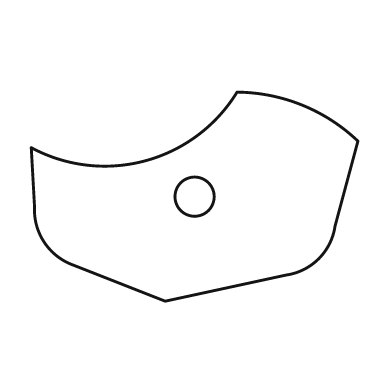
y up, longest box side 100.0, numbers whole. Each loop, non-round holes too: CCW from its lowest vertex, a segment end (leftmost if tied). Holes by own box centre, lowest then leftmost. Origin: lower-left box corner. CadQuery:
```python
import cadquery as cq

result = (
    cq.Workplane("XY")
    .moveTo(41.0, 0.0)
    .lineTo(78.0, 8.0)
    .threePointArc((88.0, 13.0), (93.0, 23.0))
    .lineTo(100.0, 49.0)
    .threePointArc((83.0, 60.0), (63.0, 64.0))
    .threePointArc((35.0, 43.0), (0.0, 47.0))
    .lineTo(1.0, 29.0)
    .threePointArc((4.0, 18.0), (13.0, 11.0))
    .close()
    .moveTo(50.0, 32.0)
    .circle(6.0)
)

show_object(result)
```